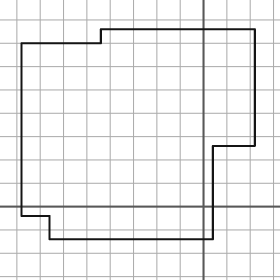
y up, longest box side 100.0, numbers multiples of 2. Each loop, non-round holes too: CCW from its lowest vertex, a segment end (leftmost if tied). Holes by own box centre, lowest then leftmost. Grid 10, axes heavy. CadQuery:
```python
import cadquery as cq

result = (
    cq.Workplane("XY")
    .moveTo(-66.0, -14.0)
    .lineTo(4.0, -14.0)
    .lineTo(4.0, 26.0)
    .lineTo(22.0, 26.0)
    .lineTo(22.0, 76.0)
    .lineTo(-44.0, 76.0)
    .lineTo(-44.0, 70.0)
    .lineTo(-78.0, 70.0)
    .lineTo(-78.0, -4.0)
    .lineTo(-66.0, -4.0)
    .close()
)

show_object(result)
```